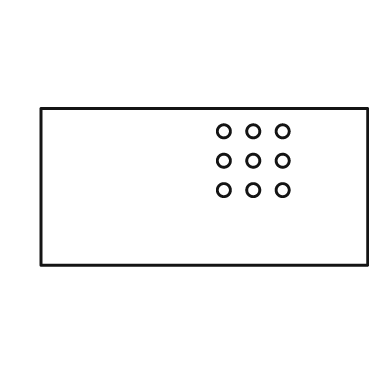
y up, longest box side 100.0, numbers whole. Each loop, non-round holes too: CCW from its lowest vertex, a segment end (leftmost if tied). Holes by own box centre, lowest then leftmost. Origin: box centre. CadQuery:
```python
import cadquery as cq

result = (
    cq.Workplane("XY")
    .moveTo(-50.0, -24.0)
    .lineTo(50.0, -24.0)
    .lineTo(50.0, 24.0)
    .lineTo(-50.0, 24.0)
    .close()
    .moveTo(6.0, -1.0)
    .circle(2.0)
    .moveTo(15.0, -1.0)
    .circle(2.0)
    .moveTo(24.0, -1.0)
    .circle(2.0)
    .moveTo(6.0, 8.0)
    .circle(2.0)
    .moveTo(15.0, 8.0)
    .circle(2.0)
    .moveTo(24.0, 8.0)
    .circle(2.0)
    .moveTo(6.0, 17.0)
    .circle(2.0)
    .moveTo(15.0, 17.0)
    .circle(2.0)
    .moveTo(24.0, 17.0)
    .circle(2.0)
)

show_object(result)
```